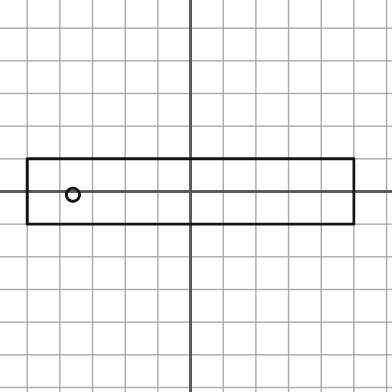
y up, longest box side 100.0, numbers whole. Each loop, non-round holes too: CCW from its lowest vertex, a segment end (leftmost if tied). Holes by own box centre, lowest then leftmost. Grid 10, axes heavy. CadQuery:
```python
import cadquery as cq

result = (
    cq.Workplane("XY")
    .moveTo(-50.0, -10.0)
    .lineTo(50.0, -10.0)
    .lineTo(50.0, 10.0)
    .lineTo(-50.0, 10.0)
    .close()
    .moveTo(-36.0, -1.0)
    .circle(2.0)
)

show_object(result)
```